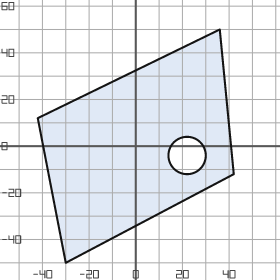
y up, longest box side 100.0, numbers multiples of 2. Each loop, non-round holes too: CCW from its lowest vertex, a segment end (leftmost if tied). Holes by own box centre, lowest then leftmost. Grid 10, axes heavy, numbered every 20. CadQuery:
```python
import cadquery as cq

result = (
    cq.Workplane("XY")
    .moveTo(-30.0, -50.0)
    .lineTo(42.0, -12.0)
    .lineTo(36.0, 50.0)
    .lineTo(-42.0, 12.0)
    .close()
    .moveTo(22.0, -4.0)
    .circle(8.0)
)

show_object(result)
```